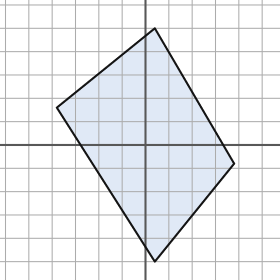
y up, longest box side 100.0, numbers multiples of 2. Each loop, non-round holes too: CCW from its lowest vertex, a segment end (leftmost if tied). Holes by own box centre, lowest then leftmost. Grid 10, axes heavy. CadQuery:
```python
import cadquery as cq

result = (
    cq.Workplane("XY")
    .moveTo(4.0, -50.0)
    .lineTo(38.0, -8.0)
    .lineTo(4.0, 50.0)
    .lineTo(-38.0, 16.0)
    .close()
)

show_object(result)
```